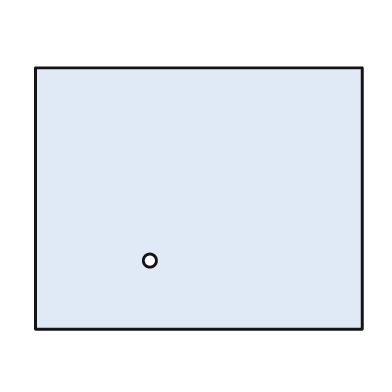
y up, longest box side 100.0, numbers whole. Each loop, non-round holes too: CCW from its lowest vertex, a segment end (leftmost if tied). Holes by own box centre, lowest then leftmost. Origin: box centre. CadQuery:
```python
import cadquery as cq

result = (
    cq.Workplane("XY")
    .moveTo(-50.0, -40.0)
    .lineTo(50.0, -40.0)
    .lineTo(50.0, 40.0)
    .lineTo(-50.0, 40.0)
    .close()
    .moveTo(-15.0, -19.0)
    .circle(2.0)
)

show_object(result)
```